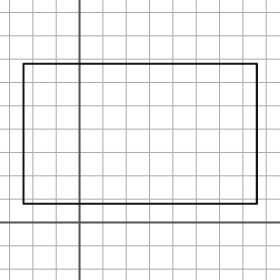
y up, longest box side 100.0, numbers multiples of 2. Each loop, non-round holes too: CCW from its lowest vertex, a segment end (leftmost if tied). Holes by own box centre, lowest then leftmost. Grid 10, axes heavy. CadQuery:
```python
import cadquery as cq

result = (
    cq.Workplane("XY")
    .moveTo(-24.0, 8.0)
    .lineTo(76.0, 8.0)
    .lineTo(76.0, 68.0)
    .lineTo(-24.0, 68.0)
    .close()
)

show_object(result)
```